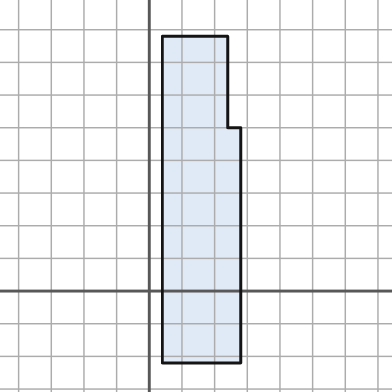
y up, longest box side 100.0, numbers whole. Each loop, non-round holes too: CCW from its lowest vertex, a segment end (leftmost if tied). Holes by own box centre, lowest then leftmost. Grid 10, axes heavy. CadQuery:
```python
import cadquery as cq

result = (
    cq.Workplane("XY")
    .moveTo(4.0, -22.0)
    .lineTo(28.0, -22.0)
    .lineTo(28.0, 50.0)
    .lineTo(24.0, 50.0)
    .lineTo(24.0, 78.0)
    .lineTo(4.0, 78.0)
    .close()
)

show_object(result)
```